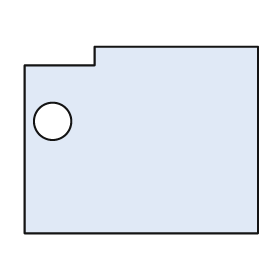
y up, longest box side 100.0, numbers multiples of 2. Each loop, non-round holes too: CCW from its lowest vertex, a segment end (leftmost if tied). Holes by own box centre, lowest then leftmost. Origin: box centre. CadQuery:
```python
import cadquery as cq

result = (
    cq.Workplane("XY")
    .moveTo(-50.0, -40.0)
    .lineTo(50.0, -40.0)
    .lineTo(50.0, 40.0)
    .lineTo(-20.0, 40.0)
    .lineTo(-20.0, 32.0)
    .lineTo(-50.0, 32.0)
    .close()
    .moveTo(-38.0, 8.0)
    .circle(8.0)
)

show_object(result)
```